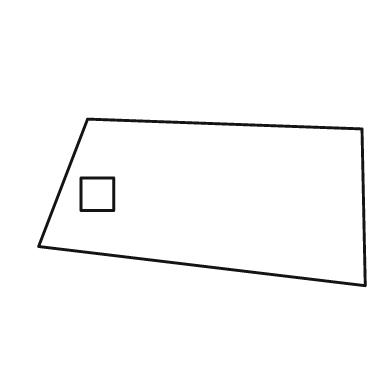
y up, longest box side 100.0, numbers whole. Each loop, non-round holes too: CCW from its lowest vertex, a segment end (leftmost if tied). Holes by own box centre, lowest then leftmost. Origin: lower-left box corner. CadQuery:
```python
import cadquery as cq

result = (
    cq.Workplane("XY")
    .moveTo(100.0, 0.0)
    .lineTo(99.0, 48.0)
    .lineTo(15.0, 51.0)
    .lineTo(0.0, 12.0)
    .close()
    .moveTo(13.0, 23.0)
    .lineTo(23.0, 23.0)
    .lineTo(23.0, 33.0)
    .lineTo(13.0, 33.0)
    .close()
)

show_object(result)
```